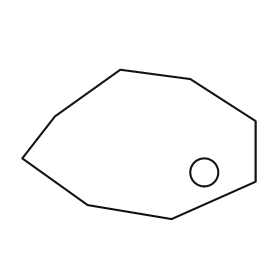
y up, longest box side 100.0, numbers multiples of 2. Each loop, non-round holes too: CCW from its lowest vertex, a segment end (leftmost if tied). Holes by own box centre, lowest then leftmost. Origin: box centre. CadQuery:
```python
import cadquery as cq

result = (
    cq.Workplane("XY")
    .moveTo(14.0, -32.0)
    .lineTo(50.0, -16.0)
    .lineTo(50.0, 10.0)
    .lineTo(22.0, 28.0)
    .lineTo(-8.0, 32.0)
    .lineTo(-36.0, 12.0)
    .lineTo(-50.0, -6.0)
    .lineTo(-22.0, -26.0)
    .close()
    .moveTo(28.0, -12.0)
    .circle(6.0)
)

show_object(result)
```